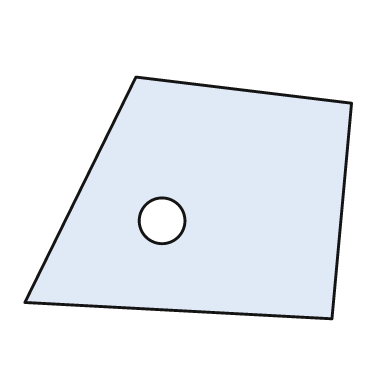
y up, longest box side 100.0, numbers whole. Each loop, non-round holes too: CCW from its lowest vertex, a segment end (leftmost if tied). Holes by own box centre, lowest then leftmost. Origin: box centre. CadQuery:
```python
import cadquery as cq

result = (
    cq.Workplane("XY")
    .moveTo(44.0, -37.0)
    .lineTo(50.0, 29.0)
    .lineTo(-16.0, 37.0)
    .lineTo(-50.0, -32.0)
    .close()
    .moveTo(-8.0, -7.0)
    .circle(7.0)
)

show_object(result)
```